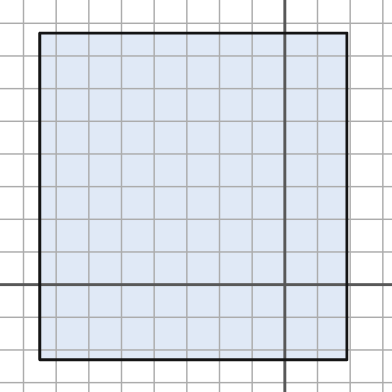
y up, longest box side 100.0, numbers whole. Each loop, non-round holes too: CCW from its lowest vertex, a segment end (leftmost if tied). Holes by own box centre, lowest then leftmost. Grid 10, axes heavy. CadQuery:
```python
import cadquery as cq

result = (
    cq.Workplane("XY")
    .moveTo(-75.0, -23.0)
    .lineTo(19.0, -23.0)
    .lineTo(19.0, 77.0)
    .lineTo(-75.0, 77.0)
    .close()
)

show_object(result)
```